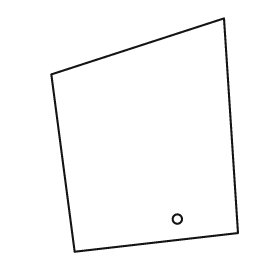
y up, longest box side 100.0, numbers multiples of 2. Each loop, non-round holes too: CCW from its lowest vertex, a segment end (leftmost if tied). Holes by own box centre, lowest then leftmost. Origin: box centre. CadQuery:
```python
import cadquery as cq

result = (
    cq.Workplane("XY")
    .moveTo(-30.0, -50.0)
    .lineTo(40.0, -42.0)
    .lineTo(34.0, 50.0)
    .lineTo(-40.0, 26.0)
    .close()
    .moveTo(14.0, -36.0)
    .circle(2.0)
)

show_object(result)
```